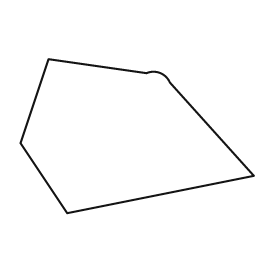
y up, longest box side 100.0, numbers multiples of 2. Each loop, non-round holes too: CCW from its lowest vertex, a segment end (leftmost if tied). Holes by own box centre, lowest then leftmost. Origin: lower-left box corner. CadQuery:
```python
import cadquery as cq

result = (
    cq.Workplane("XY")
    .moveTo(20.0, 0.0)
    .lineTo(100.0, 16.0)
    .lineTo(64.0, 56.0)
    .threePointArc((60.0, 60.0), (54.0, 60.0))
    .lineTo(12.0, 66.0)
    .lineTo(0.0, 30.0)
    .close()
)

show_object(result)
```